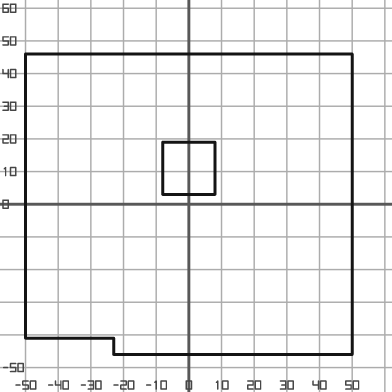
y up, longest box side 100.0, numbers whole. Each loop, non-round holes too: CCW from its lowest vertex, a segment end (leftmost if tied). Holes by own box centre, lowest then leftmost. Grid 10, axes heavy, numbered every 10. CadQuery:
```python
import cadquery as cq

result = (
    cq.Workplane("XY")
    .moveTo(-23.0, -46.0)
    .lineTo(50.0, -46.0)
    .lineTo(50.0, 46.0)
    .lineTo(-50.0, 46.0)
    .lineTo(-50.0, -41.0)
    .lineTo(-23.0, -41.0)
    .close()
    .moveTo(-8.0, 3.0)
    .lineTo(8.0, 3.0)
    .lineTo(8.0, 19.0)
    .lineTo(-8.0, 19.0)
    .close()
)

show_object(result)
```